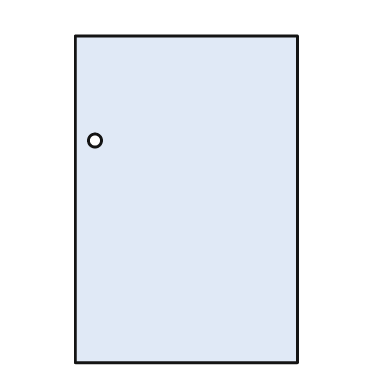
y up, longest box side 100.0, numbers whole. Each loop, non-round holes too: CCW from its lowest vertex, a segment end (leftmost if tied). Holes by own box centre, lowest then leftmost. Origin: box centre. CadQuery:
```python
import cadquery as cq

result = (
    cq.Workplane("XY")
    .moveTo(-34.0, -50.0)
    .lineTo(34.0, -50.0)
    .lineTo(34.0, 50.0)
    .lineTo(-34.0, 50.0)
    .close()
    .moveTo(-28.0, 18.0)
    .circle(2.0)
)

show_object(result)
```